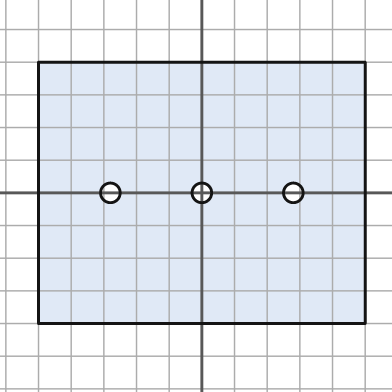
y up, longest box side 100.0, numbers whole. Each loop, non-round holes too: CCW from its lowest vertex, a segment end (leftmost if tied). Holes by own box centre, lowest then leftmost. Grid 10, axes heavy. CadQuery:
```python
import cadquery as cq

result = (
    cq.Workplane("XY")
    .moveTo(-50.0, -40.0)
    .lineTo(50.0, -40.0)
    .lineTo(50.0, 40.0)
    .lineTo(-50.0, 40.0)
    .close()
    .moveTo(-28.0, 0.0)
    .circle(3.0)
    .moveTo(0.0, 0.0)
    .circle(3.0)
    .moveTo(28.0, 0.0)
    .circle(3.0)
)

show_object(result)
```